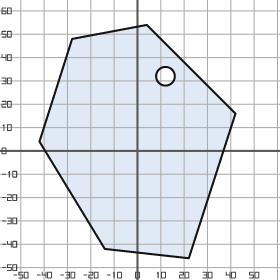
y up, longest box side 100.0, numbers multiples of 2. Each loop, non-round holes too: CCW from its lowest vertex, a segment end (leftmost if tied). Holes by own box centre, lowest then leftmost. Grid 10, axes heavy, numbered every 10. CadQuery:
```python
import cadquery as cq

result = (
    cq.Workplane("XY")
    .moveTo(22.0, -46.0)
    .lineTo(42.0, 16.0)
    .lineTo(4.0, 54.0)
    .lineTo(-28.0, 48.0)
    .lineTo(-42.0, 4.0)
    .lineTo(-14.0, -42.0)
    .close()
    .moveTo(12.0, 32.0)
    .circle(4.0)
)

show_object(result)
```